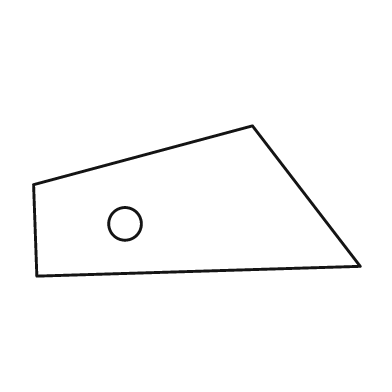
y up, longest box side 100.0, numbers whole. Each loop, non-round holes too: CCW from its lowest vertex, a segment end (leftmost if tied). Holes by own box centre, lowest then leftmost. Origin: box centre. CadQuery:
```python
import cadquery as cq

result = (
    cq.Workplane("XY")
    .moveTo(-49.0, -23.0)
    .lineTo(50.0, -20.0)
    .lineTo(17.0, 23.0)
    .lineTo(-50.0, 5.0)
    .close()
    .moveTo(-22.0, -7.0)
    .circle(5.0)
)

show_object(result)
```